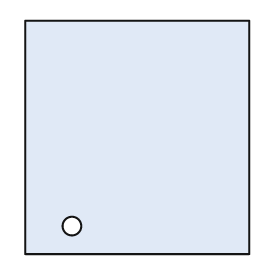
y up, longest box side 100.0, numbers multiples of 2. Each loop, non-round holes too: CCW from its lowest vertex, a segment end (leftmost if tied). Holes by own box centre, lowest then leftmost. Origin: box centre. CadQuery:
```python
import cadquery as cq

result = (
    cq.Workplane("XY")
    .moveTo(-48.0, -50.0)
    .lineTo(48.0, -50.0)
    .lineTo(48.0, 50.0)
    .lineTo(-48.0, 50.0)
    .close()
    .moveTo(-28.0, -38.0)
    .circle(4.0)
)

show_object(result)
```